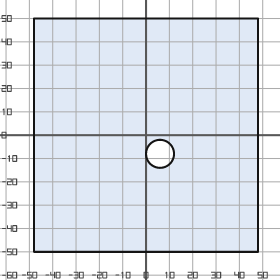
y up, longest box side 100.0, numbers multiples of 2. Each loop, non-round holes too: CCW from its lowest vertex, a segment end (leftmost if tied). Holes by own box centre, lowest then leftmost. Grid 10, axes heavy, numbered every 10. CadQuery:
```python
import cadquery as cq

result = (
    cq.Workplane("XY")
    .moveTo(-48.0, -50.0)
    .lineTo(48.0, -50.0)
    .lineTo(48.0, 50.0)
    .lineTo(-48.0, 50.0)
    .close()
    .moveTo(6.0, -8.0)
    .circle(6.0)
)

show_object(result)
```